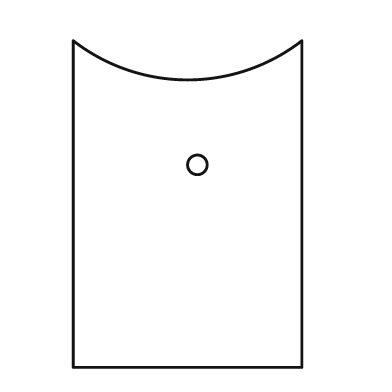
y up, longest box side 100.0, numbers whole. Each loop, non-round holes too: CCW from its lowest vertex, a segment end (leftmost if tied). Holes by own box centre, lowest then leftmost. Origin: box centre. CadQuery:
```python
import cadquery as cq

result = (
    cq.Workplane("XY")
    .moveTo(-35.0, -50.0)
    .lineTo(35.0, -50.0)
    .lineTo(35.0, 50.0)
    .threePointArc((0.0, 38.0), (-35.0, 50.0))
    .close()
    .moveTo(3.0, 12.0)
    .circle(3.0)
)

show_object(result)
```